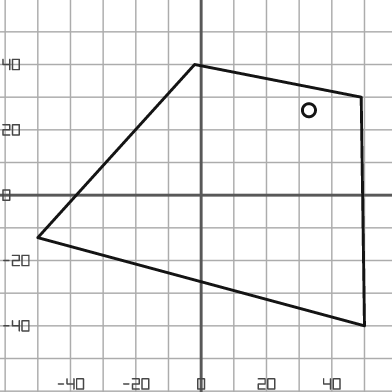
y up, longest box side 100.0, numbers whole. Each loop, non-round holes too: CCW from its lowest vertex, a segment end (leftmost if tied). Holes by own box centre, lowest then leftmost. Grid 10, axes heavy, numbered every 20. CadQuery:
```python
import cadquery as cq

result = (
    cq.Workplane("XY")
    .moveTo(50.0, -40.0)
    .lineTo(49.0, 30.0)
    .lineTo(-2.0, 40.0)
    .lineTo(-50.0, -13.0)
    .close()
    .moveTo(33.0, 26.0)
    .circle(2.0)
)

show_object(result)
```